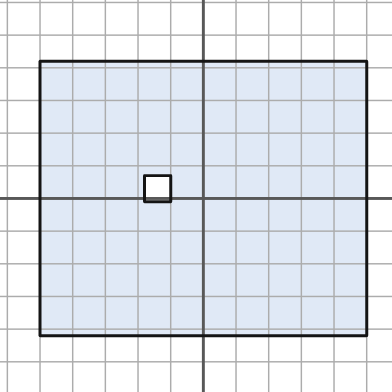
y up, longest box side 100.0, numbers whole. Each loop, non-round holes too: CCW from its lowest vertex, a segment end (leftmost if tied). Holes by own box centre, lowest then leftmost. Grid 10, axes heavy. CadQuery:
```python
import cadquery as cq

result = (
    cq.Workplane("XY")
    .moveTo(-50.0, -42.0)
    .lineTo(50.0, -42.0)
    .lineTo(50.0, 42.0)
    .lineTo(-50.0, 42.0)
    .close()
    .moveTo(-18.0, -1.0)
    .lineTo(-10.0, -1.0)
    .lineTo(-10.0, 7.0)
    .lineTo(-18.0, 7.0)
    .close()
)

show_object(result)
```